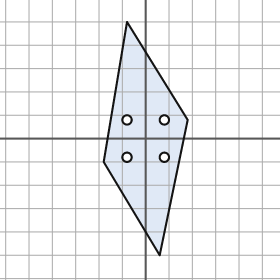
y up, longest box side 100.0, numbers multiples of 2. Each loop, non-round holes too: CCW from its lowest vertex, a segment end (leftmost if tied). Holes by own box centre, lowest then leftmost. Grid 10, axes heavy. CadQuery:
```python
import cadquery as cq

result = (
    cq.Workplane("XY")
    .moveTo(6.0, -50.0)
    .lineTo(18.0, 8.0)
    .lineTo(-8.0, 50.0)
    .lineTo(-18.0, -10.0)
    .close()
    .moveTo(-8.0, -8.0)
    .circle(2.0)
    .moveTo(8.0, -8.0)
    .circle(2.0)
    .moveTo(-8.0, 8.0)
    .circle(2.0)
    .moveTo(8.0, 8.0)
    .circle(2.0)
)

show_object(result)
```